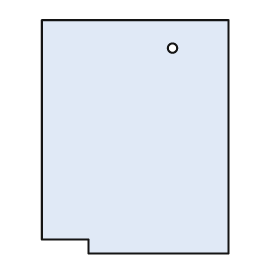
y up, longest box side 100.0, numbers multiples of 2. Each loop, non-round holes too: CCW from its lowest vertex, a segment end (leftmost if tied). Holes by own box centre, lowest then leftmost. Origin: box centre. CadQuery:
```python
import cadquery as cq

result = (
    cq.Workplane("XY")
    .moveTo(-20.0, -50.0)
    .lineTo(40.0, -50.0)
    .lineTo(40.0, 50.0)
    .lineTo(-40.0, 50.0)
    .lineTo(-40.0, -44.0)
    .lineTo(-20.0, -44.0)
    .close()
    .moveTo(16.0, 38.0)
    .circle(2.0)
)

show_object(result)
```